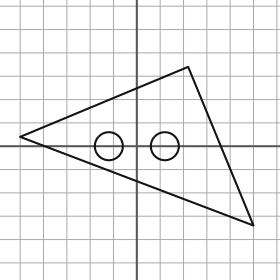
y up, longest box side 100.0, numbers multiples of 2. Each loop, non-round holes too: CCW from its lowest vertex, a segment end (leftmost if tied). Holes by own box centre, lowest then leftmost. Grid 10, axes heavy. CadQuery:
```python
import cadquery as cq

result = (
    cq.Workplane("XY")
    .moveTo(50.0, -34.0)
    .lineTo(22.0, 34.0)
    .lineTo(-50.0, 4.0)
    .close()
    .moveTo(-12.0, 0.0)
    .circle(6.0)
    .moveTo(12.0, 0.0)
    .circle(6.0)
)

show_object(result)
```